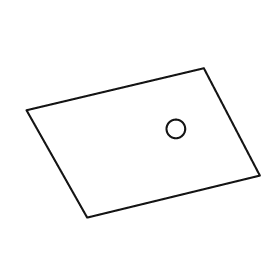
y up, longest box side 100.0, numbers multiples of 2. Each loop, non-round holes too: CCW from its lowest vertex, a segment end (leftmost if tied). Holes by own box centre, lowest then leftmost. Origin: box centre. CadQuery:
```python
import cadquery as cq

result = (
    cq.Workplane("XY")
    .moveTo(-24.0, -32.0)
    .lineTo(50.0, -14.0)
    .lineTo(26.0, 32.0)
    .lineTo(-50.0, 14.0)
    .close()
    .moveTo(14.0, 6.0)
    .circle(4.0)
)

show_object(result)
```